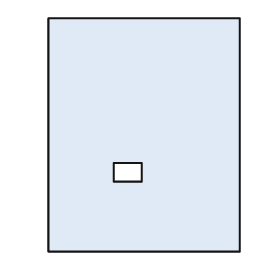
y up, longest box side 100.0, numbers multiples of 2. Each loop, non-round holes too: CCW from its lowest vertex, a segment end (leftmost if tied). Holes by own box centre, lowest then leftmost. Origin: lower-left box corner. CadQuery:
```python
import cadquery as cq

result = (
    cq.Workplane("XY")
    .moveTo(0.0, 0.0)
    .lineTo(82.0, 0.0)
    .lineTo(82.0, 100.0)
    .lineTo(0.0, 100.0)
    .close()
    .moveTo(28.0, 30.0)
    .lineTo(40.0, 30.0)
    .lineTo(40.0, 38.0)
    .lineTo(28.0, 38.0)
    .close()
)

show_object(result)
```